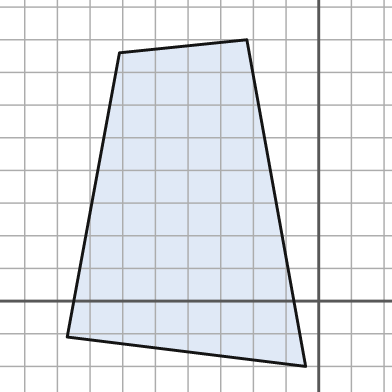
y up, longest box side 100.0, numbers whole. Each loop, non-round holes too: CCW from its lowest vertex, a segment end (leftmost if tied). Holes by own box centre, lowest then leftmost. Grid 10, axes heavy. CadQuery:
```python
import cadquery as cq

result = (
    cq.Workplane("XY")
    .moveTo(-4.0, -20.0)
    .lineTo(-22.0, 80.0)
    .lineTo(-61.0, 76.0)
    .lineTo(-77.0, -11.0)
    .close()
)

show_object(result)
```